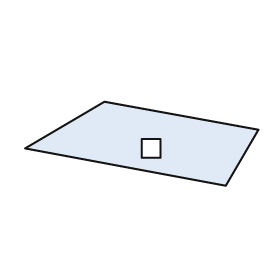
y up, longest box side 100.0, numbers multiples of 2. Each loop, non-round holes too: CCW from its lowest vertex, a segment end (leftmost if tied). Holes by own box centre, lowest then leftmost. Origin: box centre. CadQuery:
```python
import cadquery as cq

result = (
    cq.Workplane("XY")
    .moveTo(36.0, -18.0)
    .lineTo(50.0, 6.0)
    .lineTo(-16.0, 18.0)
    .lineTo(-50.0, -2.0)
    .close()
    .moveTo(0.0, -6.0)
    .lineTo(8.0, -6.0)
    .lineTo(8.0, 2.0)
    .lineTo(0.0, 2.0)
    .close()
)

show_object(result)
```